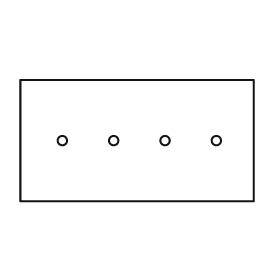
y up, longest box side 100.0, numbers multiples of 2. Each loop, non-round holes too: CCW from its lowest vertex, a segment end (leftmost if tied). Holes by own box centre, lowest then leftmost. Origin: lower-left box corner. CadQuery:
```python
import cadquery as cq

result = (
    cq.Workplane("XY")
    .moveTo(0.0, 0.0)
    .lineTo(100.0, 0.0)
    .lineTo(100.0, 52.0)
    .lineTo(0.0, 52.0)
    .close()
    .moveTo(18.0, 26.0)
    .circle(2.0)
    .moveTo(40.0, 26.0)
    .circle(2.0)
    .moveTo(62.0, 26.0)
    .circle(2.0)
    .moveTo(84.0, 26.0)
    .circle(2.0)
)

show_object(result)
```